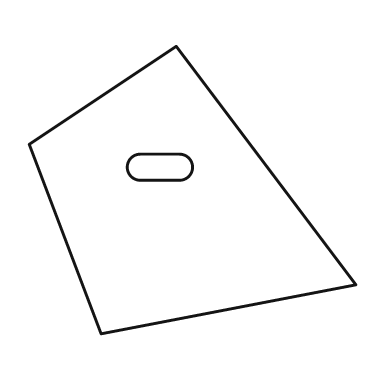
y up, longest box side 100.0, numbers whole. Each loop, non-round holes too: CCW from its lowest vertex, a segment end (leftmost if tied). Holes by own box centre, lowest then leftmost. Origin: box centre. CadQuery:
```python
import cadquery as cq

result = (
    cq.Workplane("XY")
    .moveTo(-28.0, -44.0)
    .lineTo(50.0, -29.0)
    .lineTo(-5.0, 44.0)
    .lineTo(-50.0, 14.0)
    .close()
    .moveTo(-16.0, 3.0)
    .lineTo(-4.0, 3.0)
    .threePointArc((0.0, 7.0), (-4.0, 11.0))
    .lineTo(-16.0, 11.0)
    .threePointArc((-20.0, 7.0), (-16.0, 3.0))
    .close()
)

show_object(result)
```